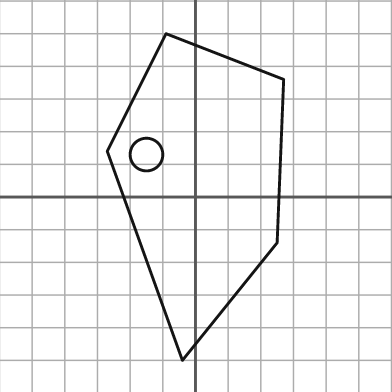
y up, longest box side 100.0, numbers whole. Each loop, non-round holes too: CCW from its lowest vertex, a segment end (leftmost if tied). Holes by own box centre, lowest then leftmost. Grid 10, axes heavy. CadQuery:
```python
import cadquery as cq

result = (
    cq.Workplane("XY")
    .moveTo(-4.0, -50.0)
    .lineTo(25.0, -14.0)
    .lineTo(27.0, 36.0)
    .lineTo(-9.0, 50.0)
    .lineTo(-27.0, 14.0)
    .close()
    .moveTo(-15.0, 13.0)
    .circle(5.0)
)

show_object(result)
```